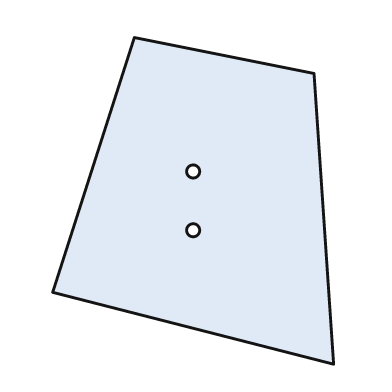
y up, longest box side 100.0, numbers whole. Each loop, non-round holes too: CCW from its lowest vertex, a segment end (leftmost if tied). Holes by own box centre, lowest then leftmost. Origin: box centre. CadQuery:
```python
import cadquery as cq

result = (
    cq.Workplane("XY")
    .moveTo(43.0, -50.0)
    .lineTo(37.0, 39.0)
    .lineTo(-18.0, 50.0)
    .lineTo(-43.0, -28.0)
    .close()
    .moveTo(0.0, -9.0)
    .circle(2.0)
    .moveTo(0.0, 9.0)
    .circle(2.0)
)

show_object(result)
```